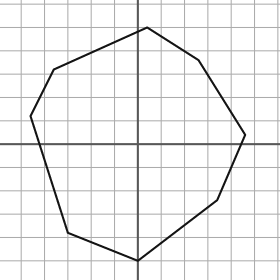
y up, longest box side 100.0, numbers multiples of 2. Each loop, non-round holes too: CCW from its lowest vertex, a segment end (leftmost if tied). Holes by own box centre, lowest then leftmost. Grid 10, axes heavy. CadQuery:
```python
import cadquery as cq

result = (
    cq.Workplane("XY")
    .moveTo(0.0, -50.0)
    .lineTo(34.0, -24.0)
    .lineTo(46.0, 4.0)
    .lineTo(26.0, 36.0)
    .lineTo(4.0, 50.0)
    .lineTo(-36.0, 32.0)
    .lineTo(-46.0, 12.0)
    .lineTo(-30.0, -38.0)
    .close()
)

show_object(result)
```